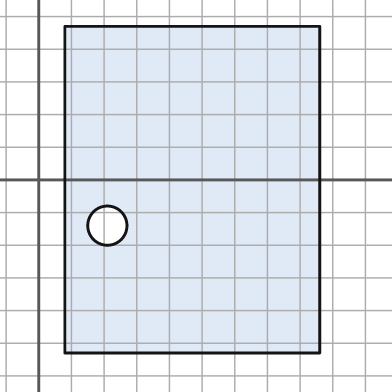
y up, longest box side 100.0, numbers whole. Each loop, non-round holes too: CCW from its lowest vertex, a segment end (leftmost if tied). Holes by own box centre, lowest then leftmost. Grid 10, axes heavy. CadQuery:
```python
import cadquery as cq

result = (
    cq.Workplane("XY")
    .moveTo(8.0, -53.0)
    .lineTo(86.0, -53.0)
    .lineTo(86.0, 47.0)
    .lineTo(8.0, 47.0)
    .close()
    .moveTo(21.0, -14.0)
    .circle(6.0)
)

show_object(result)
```